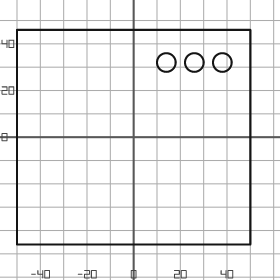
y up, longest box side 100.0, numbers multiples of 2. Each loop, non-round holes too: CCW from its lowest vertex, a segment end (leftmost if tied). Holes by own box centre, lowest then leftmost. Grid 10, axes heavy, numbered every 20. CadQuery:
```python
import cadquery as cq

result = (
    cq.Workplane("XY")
    .moveTo(-50.0, -46.0)
    .lineTo(50.0, -46.0)
    .lineTo(50.0, 46.0)
    .lineTo(-50.0, 46.0)
    .close()
    .moveTo(14.0, 32.0)
    .circle(4.0)
    .moveTo(26.0, 32.0)
    .circle(4.0)
    .moveTo(38.0, 32.0)
    .circle(4.0)
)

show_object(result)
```